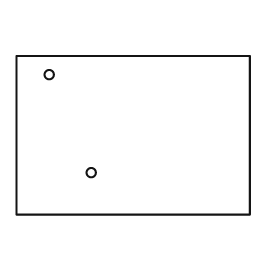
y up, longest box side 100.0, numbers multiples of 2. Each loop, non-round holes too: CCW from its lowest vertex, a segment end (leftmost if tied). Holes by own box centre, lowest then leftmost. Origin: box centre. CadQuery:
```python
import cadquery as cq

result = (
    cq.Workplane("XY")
    .moveTo(-50.0, -34.0)
    .lineTo(50.0, -34.0)
    .lineTo(50.0, 34.0)
    .lineTo(-50.0, 34.0)
    .close()
    .moveTo(-18.0, -16.0)
    .circle(2.0)
    .moveTo(-36.0, 26.0)
    .circle(2.0)
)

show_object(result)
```